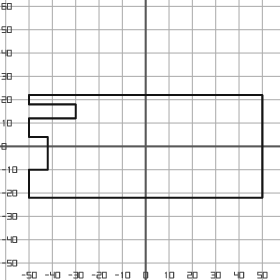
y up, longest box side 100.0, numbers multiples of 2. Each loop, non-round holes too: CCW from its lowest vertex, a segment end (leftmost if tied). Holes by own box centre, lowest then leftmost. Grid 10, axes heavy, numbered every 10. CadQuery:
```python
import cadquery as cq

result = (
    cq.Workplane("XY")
    .moveTo(-50.0, -22.0)
    .lineTo(50.0, -22.0)
    .lineTo(50.0, 22.0)
    .lineTo(-50.0, 22.0)
    .lineTo(-50.0, 18.0)
    .lineTo(-30.0, 18.0)
    .lineTo(-30.0, 12.0)
    .lineTo(-50.0, 12.0)
    .lineTo(-50.0, 4.0)
    .lineTo(-42.0, 4.0)
    .lineTo(-42.0, -10.0)
    .lineTo(-50.0, -10.0)
    .close()
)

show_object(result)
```